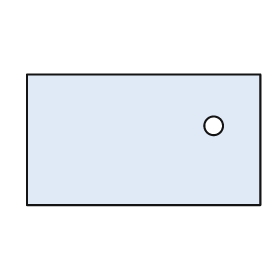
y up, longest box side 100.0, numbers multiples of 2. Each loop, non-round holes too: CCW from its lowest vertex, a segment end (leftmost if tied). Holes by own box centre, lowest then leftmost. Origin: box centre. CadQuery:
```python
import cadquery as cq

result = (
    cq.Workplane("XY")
    .moveTo(-50.0, -28.0)
    .lineTo(50.0, -28.0)
    .lineTo(50.0, 28.0)
    .lineTo(-50.0, 28.0)
    .close()
    .moveTo(30.0, 6.0)
    .circle(4.0)
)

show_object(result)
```